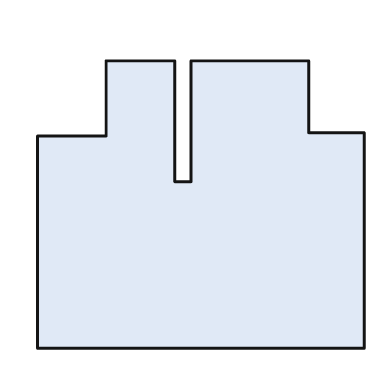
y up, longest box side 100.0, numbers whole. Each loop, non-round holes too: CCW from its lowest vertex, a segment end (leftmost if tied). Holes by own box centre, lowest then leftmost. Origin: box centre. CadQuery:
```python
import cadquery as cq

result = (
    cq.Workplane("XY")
    .moveTo(-50.0, -44.0)
    .lineTo(50.0, -44.0)
    .lineTo(50.0, 22.0)
    .lineTo(33.0, 22.0)
    .lineTo(33.0, 44.0)
    .lineTo(-3.0, 44.0)
    .lineTo(-3.0, 7.0)
    .lineTo(-8.0, 7.0)
    .lineTo(-8.0, 44.0)
    .lineTo(-29.0, 44.0)
    .lineTo(-29.0, 21.0)
    .lineTo(-50.0, 21.0)
    .close()
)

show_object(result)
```